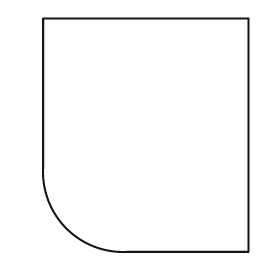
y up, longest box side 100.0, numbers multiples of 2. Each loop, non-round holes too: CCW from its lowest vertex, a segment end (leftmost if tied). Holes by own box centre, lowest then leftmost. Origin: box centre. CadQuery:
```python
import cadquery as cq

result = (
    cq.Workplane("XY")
    .moveTo(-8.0, -50.0)
    .lineTo(44.0, -50.0)
    .lineTo(44.0, 50.0)
    .lineTo(-44.0, 50.0)
    .lineTo(-44.0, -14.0)
    .threePointArc((-34.0, -40.0), (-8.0, -50.0))
    .close()
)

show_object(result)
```